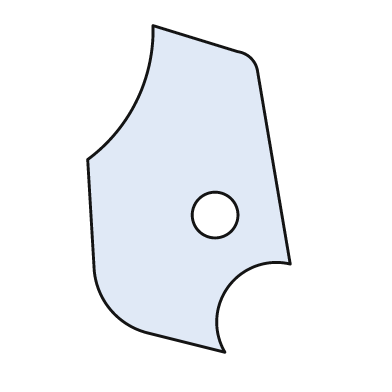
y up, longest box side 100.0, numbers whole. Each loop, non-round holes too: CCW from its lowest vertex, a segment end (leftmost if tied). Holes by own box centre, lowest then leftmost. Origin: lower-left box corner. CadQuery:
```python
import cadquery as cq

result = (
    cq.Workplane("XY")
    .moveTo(42.0, 0.0)
    .threePointArc((43.0, 20.0), (62.0, 27.0))
    .lineTo(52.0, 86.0)
    .threePointArc((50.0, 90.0), (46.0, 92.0))
    .lineTo(20.0, 100.0)
    .threePointArc((15.0, 77.0), (0.0, 59.0))
    .lineTo(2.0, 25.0)
    .threePointArc((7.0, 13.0), (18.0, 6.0))
    .close()
    .moveTo(39.0, 42.0)
    .circle(7.0)
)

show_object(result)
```